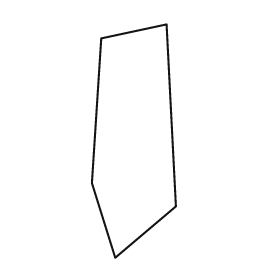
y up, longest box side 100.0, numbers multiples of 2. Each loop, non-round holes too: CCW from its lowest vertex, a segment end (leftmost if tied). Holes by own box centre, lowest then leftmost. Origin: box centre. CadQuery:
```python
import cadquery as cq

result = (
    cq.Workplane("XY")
    .moveTo(-8.0, -50.0)
    .lineTo(18.0, -28.0)
    .lineTo(14.0, 50.0)
    .lineTo(-14.0, 44.0)
    .lineTo(-18.0, -18.0)
    .close()
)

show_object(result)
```